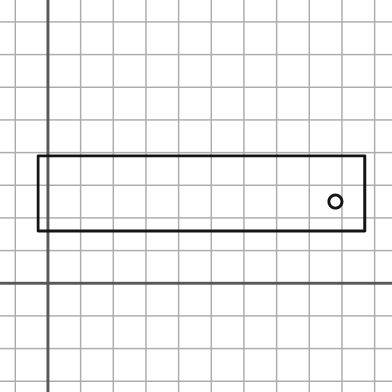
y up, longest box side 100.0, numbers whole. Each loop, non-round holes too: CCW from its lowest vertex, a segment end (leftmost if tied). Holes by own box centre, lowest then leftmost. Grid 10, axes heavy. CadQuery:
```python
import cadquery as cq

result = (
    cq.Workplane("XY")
    .moveTo(-3.0, 16.0)
    .lineTo(97.0, 16.0)
    .lineTo(97.0, 39.0)
    .lineTo(-3.0, 39.0)
    .close()
    .moveTo(88.0, 25.0)
    .circle(2.0)
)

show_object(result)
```